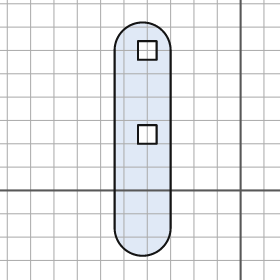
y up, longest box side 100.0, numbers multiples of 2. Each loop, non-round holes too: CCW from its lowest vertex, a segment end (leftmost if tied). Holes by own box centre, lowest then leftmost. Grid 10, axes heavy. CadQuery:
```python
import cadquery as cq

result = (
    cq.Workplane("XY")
    .moveTo(-54.0, -16.0)
    .threePointArc((-42.0, -28.0), (-30.0, -16.0))
    .lineTo(-30.0, 60.0)
    .threePointArc((-42.0, 72.0), (-54.0, 60.0))
    .close()
    .moveTo(-44.0, 20.0)
    .lineTo(-36.0, 20.0)
    .lineTo(-36.0, 28.0)
    .lineTo(-44.0, 28.0)
    .close()
    .moveTo(-44.0, 56.0)
    .lineTo(-36.0, 56.0)
    .lineTo(-36.0, 64.0)
    .lineTo(-44.0, 64.0)
    .close()
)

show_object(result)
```